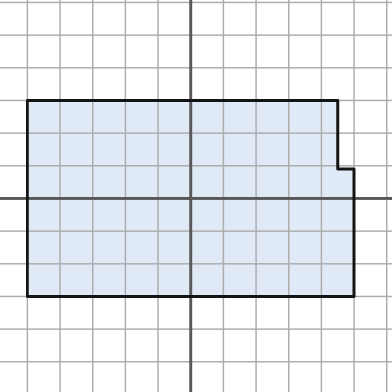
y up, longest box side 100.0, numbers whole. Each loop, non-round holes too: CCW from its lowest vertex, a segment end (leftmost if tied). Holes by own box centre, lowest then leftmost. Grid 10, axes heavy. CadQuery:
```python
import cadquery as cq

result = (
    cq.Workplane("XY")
    .moveTo(-50.0, -30.0)
    .lineTo(50.0, -30.0)
    .lineTo(50.0, 9.0)
    .lineTo(45.0, 9.0)
    .lineTo(45.0, 30.0)
    .lineTo(-50.0, 30.0)
    .close()
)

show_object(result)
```